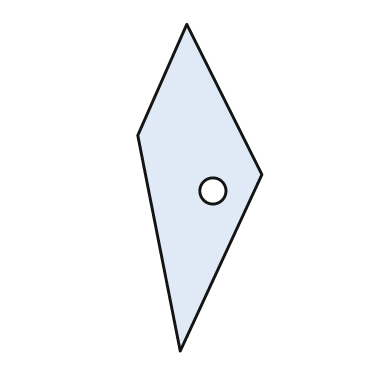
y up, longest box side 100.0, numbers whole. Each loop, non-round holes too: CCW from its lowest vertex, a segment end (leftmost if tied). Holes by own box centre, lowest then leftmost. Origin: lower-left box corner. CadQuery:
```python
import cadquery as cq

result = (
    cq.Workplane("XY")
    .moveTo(13.0, 0.0)
    .lineTo(38.0, 54.0)
    .lineTo(15.0, 100.0)
    .lineTo(0.0, 66.0)
    .close()
    .moveTo(23.0, 49.0)
    .circle(4.0)
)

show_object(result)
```